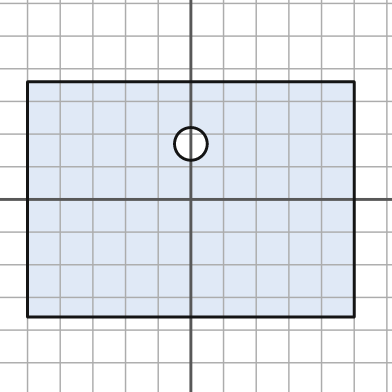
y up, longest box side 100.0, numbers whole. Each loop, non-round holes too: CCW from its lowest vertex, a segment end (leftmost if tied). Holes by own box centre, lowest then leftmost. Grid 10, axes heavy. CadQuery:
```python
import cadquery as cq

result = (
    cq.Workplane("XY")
    .moveTo(-50.0, -36.0)
    .lineTo(50.0, -36.0)
    .lineTo(50.0, 36.0)
    .lineTo(-50.0, 36.0)
    .close()
    .moveTo(0.0, 17.0)
    .circle(5.0)
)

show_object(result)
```